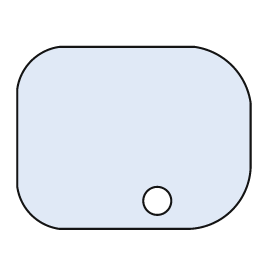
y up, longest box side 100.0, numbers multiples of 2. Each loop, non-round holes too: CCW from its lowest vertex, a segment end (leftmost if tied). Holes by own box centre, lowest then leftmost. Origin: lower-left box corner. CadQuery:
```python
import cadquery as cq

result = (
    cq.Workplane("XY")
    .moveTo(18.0, 0.0)
    .lineTo(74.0, 0.0)
    .threePointArc((92.0, 8.0), (100.0, 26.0))
    .lineTo(100.0, 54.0)
    .threePointArc((92.0, 70.0), (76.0, 78.0))
    .lineTo(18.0, 78.0)
    .threePointArc((6.0, 72.0), (0.0, 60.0))
    .lineTo(0.0, 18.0)
    .threePointArc((6.0, 6.0), (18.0, 0.0))
    .close()
    .moveTo(60.0, 12.0)
    .circle(6.0)
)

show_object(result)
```